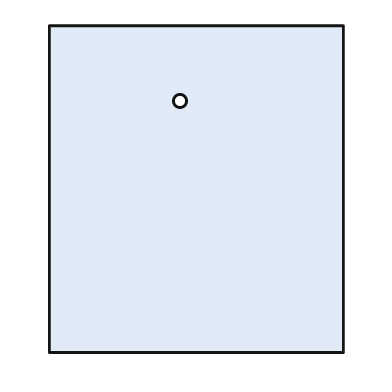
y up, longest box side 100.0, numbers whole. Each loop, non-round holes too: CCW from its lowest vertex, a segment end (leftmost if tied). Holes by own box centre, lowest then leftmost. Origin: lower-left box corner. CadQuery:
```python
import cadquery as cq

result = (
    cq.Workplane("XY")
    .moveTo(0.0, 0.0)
    .lineTo(90.0, 0.0)
    .lineTo(90.0, 100.0)
    .lineTo(0.0, 100.0)
    .close()
    .moveTo(40.0, 77.0)
    .circle(2.0)
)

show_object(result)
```